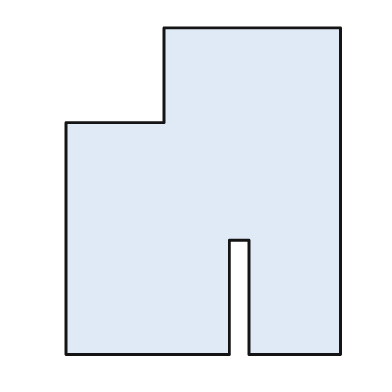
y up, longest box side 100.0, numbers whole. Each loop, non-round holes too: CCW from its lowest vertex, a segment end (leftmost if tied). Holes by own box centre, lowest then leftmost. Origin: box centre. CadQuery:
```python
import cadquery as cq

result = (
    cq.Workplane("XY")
    .moveTo(-42.0, -50.0)
    .lineTo(8.0, -50.0)
    .lineTo(8.0, -15.0)
    .lineTo(14.0, -15.0)
    .lineTo(14.0, -50.0)
    .lineTo(42.0, -50.0)
    .lineTo(42.0, 50.0)
    .lineTo(-12.0, 50.0)
    .lineTo(-12.0, 21.0)
    .lineTo(-42.0, 21.0)
    .close()
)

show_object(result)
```